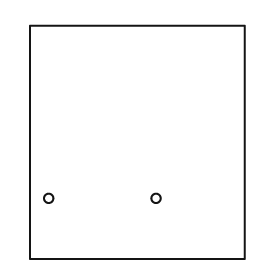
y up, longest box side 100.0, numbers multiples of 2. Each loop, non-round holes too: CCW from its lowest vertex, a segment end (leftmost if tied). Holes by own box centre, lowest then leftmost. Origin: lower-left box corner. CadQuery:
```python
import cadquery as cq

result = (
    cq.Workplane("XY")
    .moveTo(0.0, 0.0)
    .lineTo(92.0, 0.0)
    .lineTo(92.0, 100.0)
    .lineTo(0.0, 100.0)
    .close()
    .moveTo(8.0, 26.0)
    .circle(2.0)
    .moveTo(54.0, 26.0)
    .circle(2.0)
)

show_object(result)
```